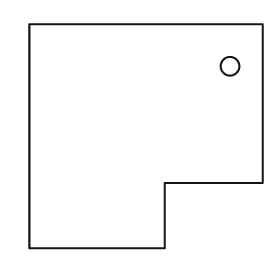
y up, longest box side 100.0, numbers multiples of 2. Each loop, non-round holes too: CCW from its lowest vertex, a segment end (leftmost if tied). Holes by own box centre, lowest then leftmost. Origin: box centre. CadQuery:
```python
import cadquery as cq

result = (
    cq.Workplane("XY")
    .moveTo(-50.0, -48.0)
    .lineTo(8.0, -48.0)
    .lineTo(8.0, -20.0)
    .lineTo(50.0, -20.0)
    .lineTo(50.0, 48.0)
    .lineTo(-50.0, 48.0)
    .close()
    .moveTo(36.0, 30.0)
    .circle(4.0)
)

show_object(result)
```